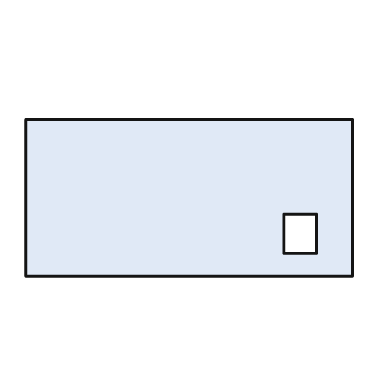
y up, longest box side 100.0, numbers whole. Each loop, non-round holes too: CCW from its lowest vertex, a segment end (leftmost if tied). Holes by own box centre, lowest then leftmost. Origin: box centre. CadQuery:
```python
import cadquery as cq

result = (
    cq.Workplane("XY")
    .moveTo(-50.0, -24.0)
    .lineTo(50.0, -24.0)
    .lineTo(50.0, 24.0)
    .lineTo(-50.0, 24.0)
    .close()
    .moveTo(29.0, -17.0)
    .lineTo(39.0, -17.0)
    .lineTo(39.0, -5.0)
    .lineTo(29.0, -5.0)
    .close()
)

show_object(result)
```